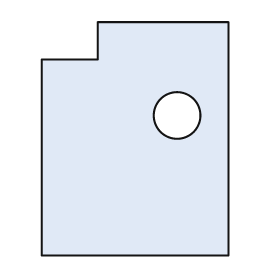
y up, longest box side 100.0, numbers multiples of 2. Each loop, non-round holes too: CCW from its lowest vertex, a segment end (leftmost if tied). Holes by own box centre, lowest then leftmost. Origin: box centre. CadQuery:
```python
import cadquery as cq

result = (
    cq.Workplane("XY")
    .moveTo(-40.0, -50.0)
    .lineTo(40.0, -50.0)
    .lineTo(40.0, 50.0)
    .lineTo(-16.0, 50.0)
    .lineTo(-16.0, 34.0)
    .lineTo(-40.0, 34.0)
    .close()
    .moveTo(18.0, 10.0)
    .circle(10.0)
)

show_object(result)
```